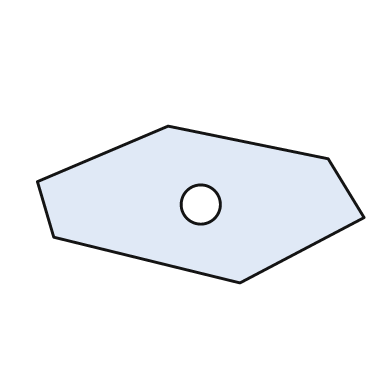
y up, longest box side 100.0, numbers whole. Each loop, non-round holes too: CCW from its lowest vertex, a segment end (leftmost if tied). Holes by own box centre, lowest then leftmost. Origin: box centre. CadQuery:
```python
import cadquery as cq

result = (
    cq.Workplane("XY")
    .moveTo(12.0, -24.0)
    .lineTo(50.0, -4.0)
    .lineTo(39.0, 14.0)
    .lineTo(-10.0, 24.0)
    .lineTo(-50.0, 7.0)
    .lineTo(-45.0, -10.0)
    .close()
    .moveTo(0.0, 0.0)
    .circle(6.0)
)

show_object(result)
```